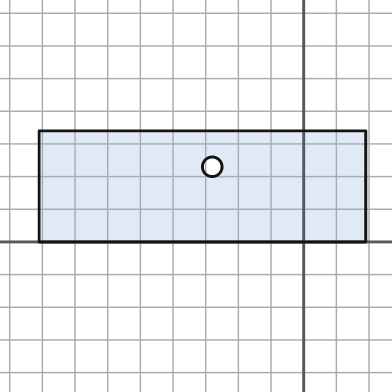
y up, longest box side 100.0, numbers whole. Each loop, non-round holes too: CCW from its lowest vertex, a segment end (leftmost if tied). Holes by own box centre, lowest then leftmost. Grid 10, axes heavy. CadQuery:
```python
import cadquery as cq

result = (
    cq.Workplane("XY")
    .moveTo(-81.0, 0.0)
    .lineTo(19.0, 0.0)
    .lineTo(19.0, 34.0)
    .lineTo(-81.0, 34.0)
    .close()
    .moveTo(-28.0, 23.0)
    .circle(3.0)
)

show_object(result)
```